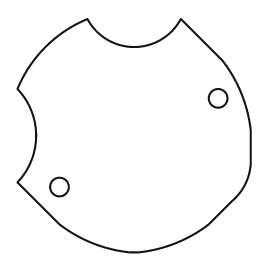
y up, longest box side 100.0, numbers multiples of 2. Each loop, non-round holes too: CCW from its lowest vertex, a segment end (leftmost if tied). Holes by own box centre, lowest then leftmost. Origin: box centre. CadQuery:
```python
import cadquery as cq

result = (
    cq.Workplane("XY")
    .moveTo(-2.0, -50.0)
    .lineTo(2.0, -50.0)
    .threePointArc((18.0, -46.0), (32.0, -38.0))
    .lineTo(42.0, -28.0)
    .threePointArc((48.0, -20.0), (50.0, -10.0))
    .lineTo(50.0, 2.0)
    .threePointArc((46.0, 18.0), (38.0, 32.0))
    .lineTo(20.0, 50.0)
    .threePointArc((0.0, 38.0), (-20.0, 50.0))
    .threePointArc((-38.0, 38.0), (-50.0, 20.0))
    .threePointArc((-42.0, 0.0), (-50.0, -20.0))
    .lineTo(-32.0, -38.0)
    .threePointArc((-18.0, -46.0), (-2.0, -50.0))
    .close()
    .moveTo(-32.0, -22.0)
    .circle(4.0)
    .moveTo(36.0, 16.0)
    .circle(4.0)
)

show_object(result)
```